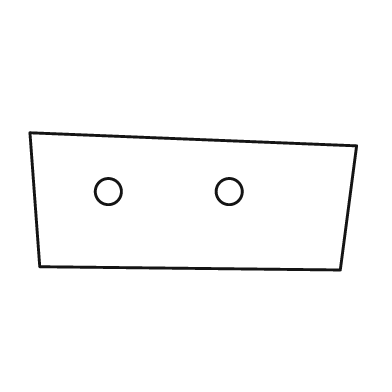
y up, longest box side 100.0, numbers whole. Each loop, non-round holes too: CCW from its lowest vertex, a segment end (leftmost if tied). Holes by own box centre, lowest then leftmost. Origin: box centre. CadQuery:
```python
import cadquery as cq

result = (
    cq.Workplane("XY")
    .moveTo(45.0, -21.0)
    .lineTo(50.0, 17.0)
    .lineTo(-50.0, 21.0)
    .lineTo(-47.0, -20.0)
    .close()
    .moveTo(-26.0, 3.0)
    .circle(4.0)
    .moveTo(11.0, 3.0)
    .circle(4.0)
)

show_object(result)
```